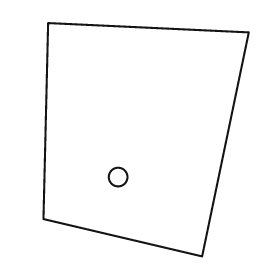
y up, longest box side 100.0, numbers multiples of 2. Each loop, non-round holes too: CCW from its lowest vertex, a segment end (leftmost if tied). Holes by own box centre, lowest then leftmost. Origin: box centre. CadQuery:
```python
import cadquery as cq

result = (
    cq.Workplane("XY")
    .moveTo(24.0, -50.0)
    .lineTo(44.0, 46.0)
    .lineTo(-42.0, 50.0)
    .lineTo(-44.0, -34.0)
    .close()
    .moveTo(-12.0, -16.0)
    .circle(4.0)
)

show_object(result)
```